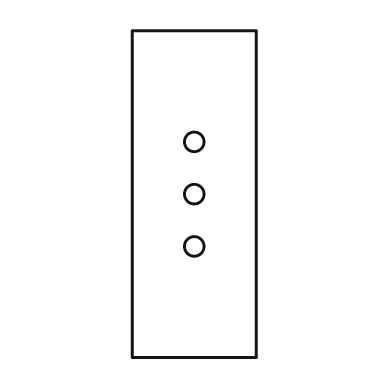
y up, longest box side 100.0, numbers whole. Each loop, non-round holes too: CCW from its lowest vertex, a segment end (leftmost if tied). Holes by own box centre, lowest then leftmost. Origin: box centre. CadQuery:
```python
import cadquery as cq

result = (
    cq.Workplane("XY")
    .moveTo(-19.0, -50.0)
    .lineTo(19.0, -50.0)
    .lineTo(19.0, 50.0)
    .lineTo(-19.0, 50.0)
    .close()
    .moveTo(0.0, -16.0)
    .circle(3.0)
    .moveTo(0.0, 0.0)
    .circle(3.0)
    .moveTo(0.0, 16.0)
    .circle(3.0)
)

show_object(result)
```